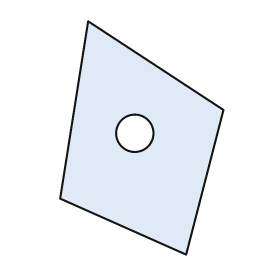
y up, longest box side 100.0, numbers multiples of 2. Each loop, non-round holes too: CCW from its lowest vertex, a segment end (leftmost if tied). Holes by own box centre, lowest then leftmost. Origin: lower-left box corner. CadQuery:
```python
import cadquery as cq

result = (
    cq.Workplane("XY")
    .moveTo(54.0, 0.0)
    .lineTo(70.0, 62.0)
    .lineTo(12.0, 100.0)
    .lineTo(0.0, 24.0)
    .close()
    .moveTo(32.0, 52.0)
    .circle(8.0)
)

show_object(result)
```